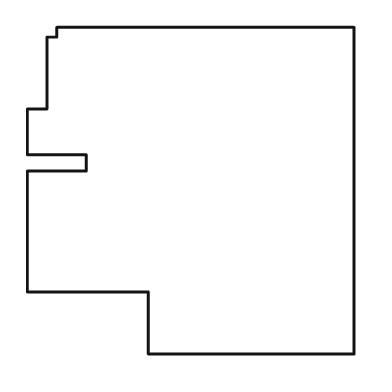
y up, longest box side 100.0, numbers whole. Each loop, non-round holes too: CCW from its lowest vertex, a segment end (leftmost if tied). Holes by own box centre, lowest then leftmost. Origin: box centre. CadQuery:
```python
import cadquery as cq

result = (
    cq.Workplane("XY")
    .moveTo(-13.0, -50.0)
    .lineTo(50.0, -50.0)
    .lineTo(50.0, 50.0)
    .lineTo(-41.0, 50.0)
    .lineTo(-41.0, 47.0)
    .lineTo(-44.0, 47.0)
    .lineTo(-44.0, 25.0)
    .lineTo(-50.0, 25.0)
    .lineTo(-50.0, 11.0)
    .lineTo(-32.0, 11.0)
    .lineTo(-32.0, 6.0)
    .lineTo(-50.0, 6.0)
    .lineTo(-50.0, -31.0)
    .lineTo(-13.0, -31.0)
    .close()
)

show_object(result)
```